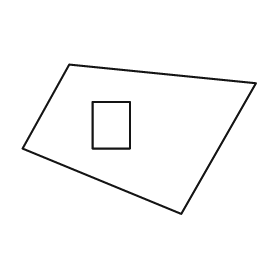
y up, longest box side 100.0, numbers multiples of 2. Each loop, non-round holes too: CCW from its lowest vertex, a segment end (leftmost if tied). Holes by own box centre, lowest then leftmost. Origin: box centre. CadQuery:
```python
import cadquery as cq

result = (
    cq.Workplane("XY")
    .moveTo(18.0, -32.0)
    .lineTo(50.0, 24.0)
    .lineTo(-30.0, 32.0)
    .lineTo(-50.0, -4.0)
    .close()
    .moveTo(-20.0, -4.0)
    .lineTo(-4.0, -4.0)
    .lineTo(-4.0, 16.0)
    .lineTo(-20.0, 16.0)
    .close()
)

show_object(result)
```